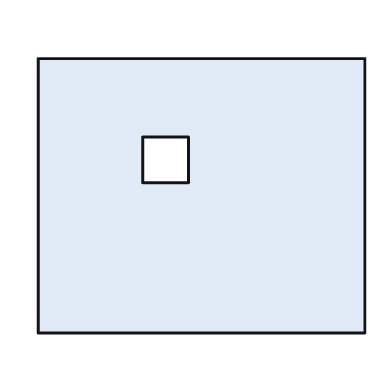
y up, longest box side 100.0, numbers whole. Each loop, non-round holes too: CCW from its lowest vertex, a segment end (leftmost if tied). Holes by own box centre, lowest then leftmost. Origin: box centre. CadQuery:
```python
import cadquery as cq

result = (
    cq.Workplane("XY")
    .moveTo(-50.0, -42.0)
    .lineTo(50.0, -42.0)
    .lineTo(50.0, 42.0)
    .lineTo(-50.0, 42.0)
    .close()
    .moveTo(-18.0, 4.0)
    .lineTo(-4.0, 4.0)
    .lineTo(-4.0, 18.0)
    .lineTo(-18.0, 18.0)
    .close()
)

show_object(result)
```